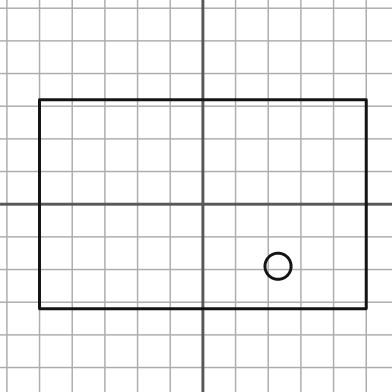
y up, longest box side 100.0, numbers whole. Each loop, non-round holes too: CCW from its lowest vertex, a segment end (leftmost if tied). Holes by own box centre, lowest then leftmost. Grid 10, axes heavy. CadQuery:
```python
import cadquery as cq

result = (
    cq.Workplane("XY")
    .moveTo(-50.0, -32.0)
    .lineTo(50.0, -32.0)
    .lineTo(50.0, 32.0)
    .lineTo(-50.0, 32.0)
    .close()
    .moveTo(23.0, -19.0)
    .circle(4.0)
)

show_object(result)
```